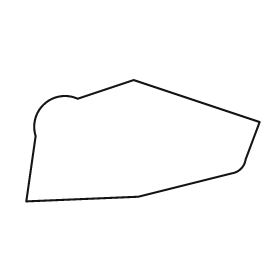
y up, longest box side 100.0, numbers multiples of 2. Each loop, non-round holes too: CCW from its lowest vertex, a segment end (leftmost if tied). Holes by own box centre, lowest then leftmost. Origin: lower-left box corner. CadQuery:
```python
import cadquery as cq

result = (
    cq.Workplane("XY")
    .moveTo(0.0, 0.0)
    .lineTo(48.0, 2.0)
    .lineTo(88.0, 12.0)
    .threePointArc((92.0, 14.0), (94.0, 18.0))
    .lineTo(100.0, 34.0)
    .lineTo(46.0, 52.0)
    .lineTo(22.0, 44.0)
    .threePointArc((8.0, 42.0), (4.0, 28.0))
    .close()
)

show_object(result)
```